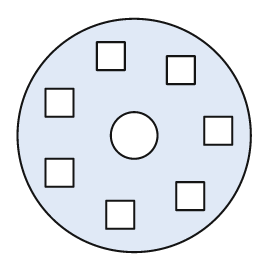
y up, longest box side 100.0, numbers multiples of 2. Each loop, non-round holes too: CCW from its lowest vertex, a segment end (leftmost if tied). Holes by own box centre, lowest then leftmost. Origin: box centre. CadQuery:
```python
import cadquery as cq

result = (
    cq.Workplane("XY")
    .moveTo(0.0, 0.0)
    .circle(50.0)
    .moveTo(-12.0, -40.0)
    .lineTo(0.0, -40.0)
    .lineTo(0.0, -28.0)
    .lineTo(-12.0, -28.0)
    .close()
    .moveTo(18.0, -32.0)
    .lineTo(30.0, -32.0)
    .lineTo(30.0, -20.0)
    .lineTo(18.0, -20.0)
    .close()
    .moveTo(-38.0, -22.0)
    .lineTo(-26.0, -22.0)
    .lineTo(-26.0, -10.0)
    .lineTo(-38.0, -10.0)
    .close()
    .moveTo(0.0, 0.0)
    .circle(10.0)
    .moveTo(30.0, -4.0)
    .lineTo(42.0, -4.0)
    .lineTo(42.0, 8.0)
    .lineTo(30.0, 8.0)
    .close()
    .moveTo(-38.0, 8.0)
    .lineTo(-26.0, 8.0)
    .lineTo(-26.0, 20.0)
    .lineTo(-38.0, 20.0)
    .close()
    .moveTo(14.0, 22.0)
    .lineTo(26.0, 22.0)
    .lineTo(26.0, 34.0)
    .lineTo(14.0, 34.0)
    .close()
    .moveTo(-16.0, 28.0)
    .lineTo(-4.0, 28.0)
    .lineTo(-4.0, 40.0)
    .lineTo(-16.0, 40.0)
    .close()
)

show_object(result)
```